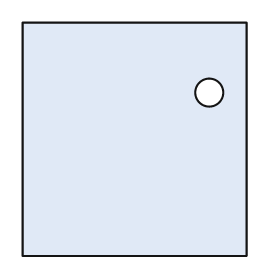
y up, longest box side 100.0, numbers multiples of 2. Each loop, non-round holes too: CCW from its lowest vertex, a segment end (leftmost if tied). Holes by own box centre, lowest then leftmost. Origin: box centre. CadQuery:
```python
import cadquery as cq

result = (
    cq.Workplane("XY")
    .moveTo(-48.0, -50.0)
    .lineTo(48.0, -50.0)
    .lineTo(48.0, 50.0)
    .lineTo(-48.0, 50.0)
    .close()
    .moveTo(32.0, 20.0)
    .circle(6.0)
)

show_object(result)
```